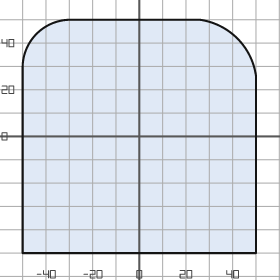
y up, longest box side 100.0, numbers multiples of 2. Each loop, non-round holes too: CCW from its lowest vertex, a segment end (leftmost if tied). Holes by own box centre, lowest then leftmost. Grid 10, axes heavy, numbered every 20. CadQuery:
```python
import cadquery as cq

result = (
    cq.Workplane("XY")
    .moveTo(-50.0, -50.0)
    .lineTo(50.0, -50.0)
    .lineTo(50.0, 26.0)
    .threePointArc((42.0, 42.0), (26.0, 50.0))
    .lineTo(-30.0, 50.0)
    .threePointArc((-44.0, 44.0), (-50.0, 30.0))
    .close()
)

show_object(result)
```